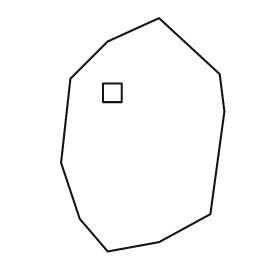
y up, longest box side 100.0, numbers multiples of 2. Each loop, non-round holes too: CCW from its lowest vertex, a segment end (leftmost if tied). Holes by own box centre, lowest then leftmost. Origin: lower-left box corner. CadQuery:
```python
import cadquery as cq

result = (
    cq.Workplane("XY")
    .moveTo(20.0, 0.0)
    .lineTo(42.0, 4.0)
    .lineTo(64.0, 16.0)
    .lineTo(70.0, 60.0)
    .lineTo(68.0, 76.0)
    .lineTo(42.0, 100.0)
    .lineTo(20.0, 90.0)
    .lineTo(4.0, 74.0)
    .lineTo(0.0, 38.0)
    .lineTo(8.0, 14.0)
    .close()
    .moveTo(18.0, 64.0)
    .lineTo(26.0, 64.0)
    .lineTo(26.0, 72.0)
    .lineTo(18.0, 72.0)
    .close()
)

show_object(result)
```